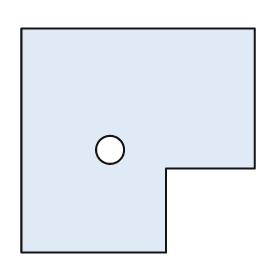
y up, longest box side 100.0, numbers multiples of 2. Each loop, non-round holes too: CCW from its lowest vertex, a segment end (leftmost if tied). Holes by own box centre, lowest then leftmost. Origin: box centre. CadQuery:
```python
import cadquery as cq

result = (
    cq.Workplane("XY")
    .moveTo(-50.0, -48.0)
    .lineTo(12.0, -48.0)
    .lineTo(12.0, -12.0)
    .lineTo(50.0, -12.0)
    .lineTo(50.0, 48.0)
    .lineTo(-50.0, 48.0)
    .close()
    .moveTo(-12.0, -4.0)
    .circle(6.0)
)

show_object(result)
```